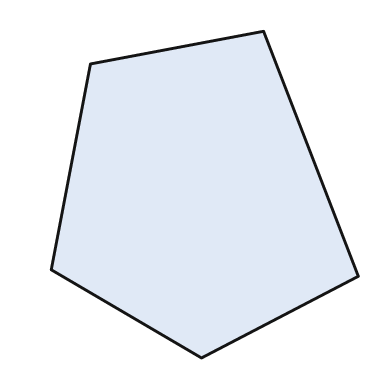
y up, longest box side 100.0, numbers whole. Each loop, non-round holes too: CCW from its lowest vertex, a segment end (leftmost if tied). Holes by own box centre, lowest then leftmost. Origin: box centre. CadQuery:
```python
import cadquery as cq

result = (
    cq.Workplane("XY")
    .moveTo(-1.0, -50.0)
    .lineTo(47.0, -25.0)
    .lineTo(18.0, 50.0)
    .lineTo(-35.0, 40.0)
    .lineTo(-47.0, -23.0)
    .close()
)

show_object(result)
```